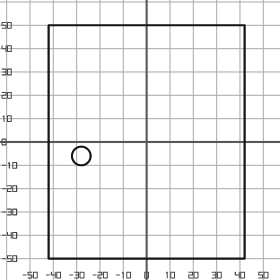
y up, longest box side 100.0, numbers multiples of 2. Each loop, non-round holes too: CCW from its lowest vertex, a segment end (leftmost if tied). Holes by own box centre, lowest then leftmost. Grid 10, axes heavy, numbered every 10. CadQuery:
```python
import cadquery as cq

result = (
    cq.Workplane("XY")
    .moveTo(-42.0, -50.0)
    .lineTo(42.0, -50.0)
    .lineTo(42.0, 50.0)
    .lineTo(-42.0, 50.0)
    .close()
    .moveTo(-28.0, -6.0)
    .circle(4.0)
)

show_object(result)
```